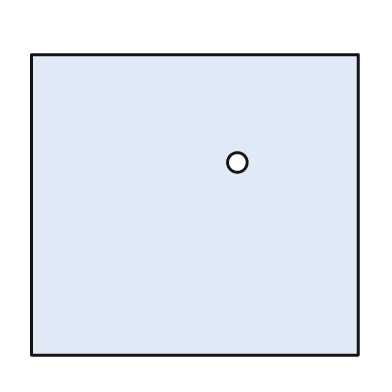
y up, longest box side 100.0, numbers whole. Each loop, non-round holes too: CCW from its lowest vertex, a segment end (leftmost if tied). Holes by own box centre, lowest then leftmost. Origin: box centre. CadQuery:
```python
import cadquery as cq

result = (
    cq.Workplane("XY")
    .moveTo(-50.0, -46.0)
    .lineTo(50.0, -46.0)
    .lineTo(50.0, 46.0)
    .lineTo(-50.0, 46.0)
    .close()
    .moveTo(13.0, 13.0)
    .circle(3.0)
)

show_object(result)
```